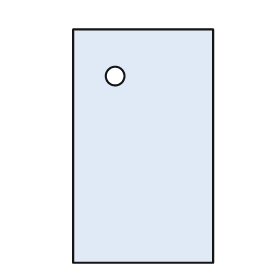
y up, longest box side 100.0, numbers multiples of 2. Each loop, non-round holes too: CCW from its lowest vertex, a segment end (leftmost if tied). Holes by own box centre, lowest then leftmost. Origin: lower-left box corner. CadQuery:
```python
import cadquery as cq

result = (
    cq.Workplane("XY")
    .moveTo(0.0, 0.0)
    .lineTo(60.0, 0.0)
    .lineTo(60.0, 100.0)
    .lineTo(0.0, 100.0)
    .close()
    .moveTo(18.0, 80.0)
    .circle(4.0)
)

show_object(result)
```